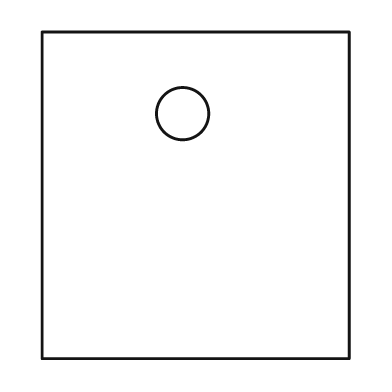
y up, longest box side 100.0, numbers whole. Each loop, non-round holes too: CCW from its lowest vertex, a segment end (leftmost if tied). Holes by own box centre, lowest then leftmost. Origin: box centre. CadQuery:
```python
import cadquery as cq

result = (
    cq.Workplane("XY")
    .moveTo(-47.0, -50.0)
    .lineTo(47.0, -50.0)
    .lineTo(47.0, 50.0)
    .lineTo(-47.0, 50.0)
    .close()
    .moveTo(-4.0, 25.0)
    .circle(8.0)
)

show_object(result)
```